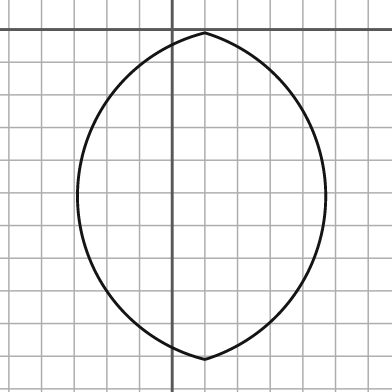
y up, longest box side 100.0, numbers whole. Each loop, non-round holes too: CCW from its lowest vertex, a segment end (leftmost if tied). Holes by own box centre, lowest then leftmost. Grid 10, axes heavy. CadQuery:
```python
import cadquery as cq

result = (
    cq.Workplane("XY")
    .moveTo(10.0, -101.0)
    .threePointArc((47.0, -51.0), (10.0, -1.0))
    .threePointArc((-29.0, -51.0), (10.0, -101.0))
    .close()
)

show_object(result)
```